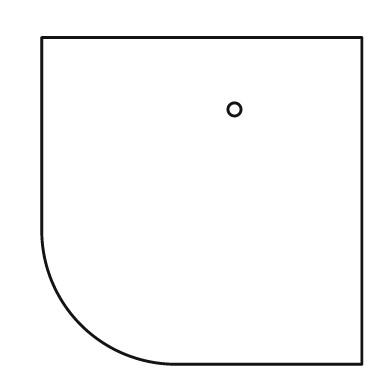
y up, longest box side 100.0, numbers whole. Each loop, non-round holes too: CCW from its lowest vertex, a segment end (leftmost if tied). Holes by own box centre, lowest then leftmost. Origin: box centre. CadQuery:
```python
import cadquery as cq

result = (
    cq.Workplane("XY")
    .moveTo(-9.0, -50.0)
    .lineTo(49.0, -50.0)
    .lineTo(49.0, 50.0)
    .lineTo(-49.0, 50.0)
    .lineTo(-49.0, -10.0)
    .threePointArc((-37.0, -38.0), (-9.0, -50.0))
    .close()
    .moveTo(10.0, 28.0)
    .circle(2.0)
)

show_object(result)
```